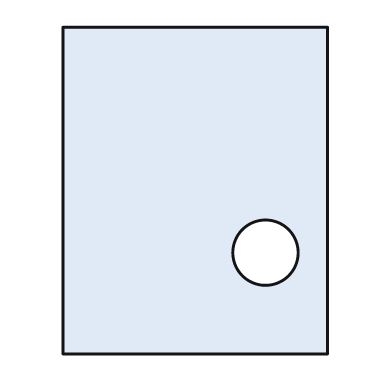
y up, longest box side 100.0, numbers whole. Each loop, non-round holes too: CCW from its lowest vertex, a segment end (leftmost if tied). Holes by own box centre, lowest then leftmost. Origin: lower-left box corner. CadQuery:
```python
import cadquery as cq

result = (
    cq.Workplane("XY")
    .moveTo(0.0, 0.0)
    .lineTo(81.0, 0.0)
    .lineTo(81.0, 100.0)
    .lineTo(0.0, 100.0)
    .close()
    .moveTo(62.0, 31.0)
    .circle(10.0)
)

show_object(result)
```